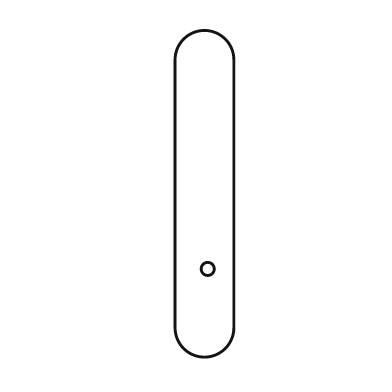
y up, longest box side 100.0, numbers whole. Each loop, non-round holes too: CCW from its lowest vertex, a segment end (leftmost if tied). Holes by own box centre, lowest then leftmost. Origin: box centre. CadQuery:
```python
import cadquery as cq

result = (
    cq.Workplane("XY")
    .moveTo(-9.0, -41.0)
    .threePointArc((0.0, -50.0), (9.0, -41.0))
    .lineTo(9.0, 41.0)
    .threePointArc((0.0, 50.0), (-9.0, 41.0))
    .close()
    .moveTo(1.0, -23.0)
    .circle(2.0)
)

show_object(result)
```